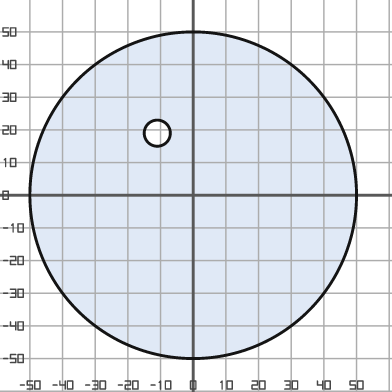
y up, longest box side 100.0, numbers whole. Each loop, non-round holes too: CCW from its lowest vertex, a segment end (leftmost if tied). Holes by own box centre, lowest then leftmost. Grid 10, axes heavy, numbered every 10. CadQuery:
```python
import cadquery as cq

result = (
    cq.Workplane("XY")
    .moveTo(0.0, 0.0)
    .circle(50.0)
    .moveTo(-11.0, 19.0)
    .circle(4.0)
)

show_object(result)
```